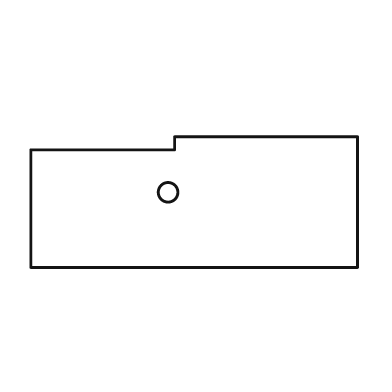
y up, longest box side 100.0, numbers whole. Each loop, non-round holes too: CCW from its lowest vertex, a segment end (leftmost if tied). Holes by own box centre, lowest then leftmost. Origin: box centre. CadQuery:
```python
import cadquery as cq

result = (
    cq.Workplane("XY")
    .moveTo(-50.0, -20.0)
    .lineTo(50.0, -20.0)
    .lineTo(50.0, 20.0)
    .lineTo(-6.0, 20.0)
    .lineTo(-6.0, 16.0)
    .lineTo(-50.0, 16.0)
    .close()
    .moveTo(-8.0, 3.0)
    .circle(3.0)
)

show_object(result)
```